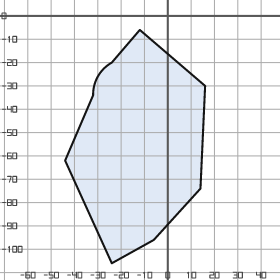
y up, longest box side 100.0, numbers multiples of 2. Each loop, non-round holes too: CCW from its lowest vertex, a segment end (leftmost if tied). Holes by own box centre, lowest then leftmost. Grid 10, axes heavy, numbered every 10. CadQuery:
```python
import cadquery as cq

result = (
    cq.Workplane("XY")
    .moveTo(-24.0, -106.0)
    .lineTo(-6.0, -96.0)
    .lineTo(14.0, -74.0)
    .lineTo(16.0, -30.0)
    .lineTo(-12.0, -6.0)
    .lineTo(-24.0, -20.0)
    .threePointArc((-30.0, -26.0), (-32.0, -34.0))
    .lineTo(-44.0, -62.0)
    .close()
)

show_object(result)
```